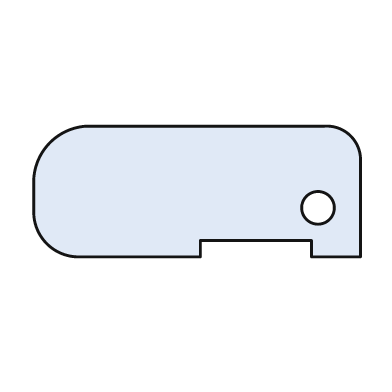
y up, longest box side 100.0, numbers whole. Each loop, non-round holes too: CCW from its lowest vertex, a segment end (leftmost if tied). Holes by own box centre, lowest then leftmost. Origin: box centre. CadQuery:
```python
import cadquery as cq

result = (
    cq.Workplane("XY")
    .moveTo(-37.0, -20.0)
    .lineTo(1.0, -20.0)
    .lineTo(1.0, -15.0)
    .lineTo(35.0, -15.0)
    .lineTo(35.0, -20.0)
    .lineTo(50.0, -20.0)
    .lineTo(50.0, 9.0)
    .threePointArc((47.0, 17.0), (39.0, 20.0))
    .lineTo(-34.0, 20.0)
    .threePointArc((-45.0, 15.0), (-50.0, 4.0))
    .lineTo(-50.0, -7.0)
    .threePointArc((-46.0, -16.0), (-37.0, -20.0))
    .close()
    .moveTo(37.0, -5.0)
    .circle(5.0)
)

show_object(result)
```